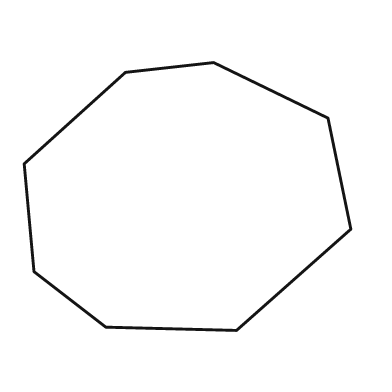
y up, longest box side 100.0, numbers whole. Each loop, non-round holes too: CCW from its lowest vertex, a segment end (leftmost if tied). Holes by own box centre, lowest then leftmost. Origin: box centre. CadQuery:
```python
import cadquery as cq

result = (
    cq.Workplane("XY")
    .moveTo(15.0, -41.0)
    .lineTo(50.0, -10.0)
    .lineTo(43.0, 24.0)
    .lineTo(8.0, 41.0)
    .lineTo(-19.0, 38.0)
    .lineTo(-50.0, 10.0)
    .lineTo(-47.0, -23.0)
    .lineTo(-25.0, -40.0)
    .close()
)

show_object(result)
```